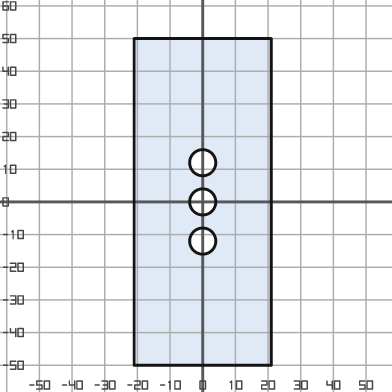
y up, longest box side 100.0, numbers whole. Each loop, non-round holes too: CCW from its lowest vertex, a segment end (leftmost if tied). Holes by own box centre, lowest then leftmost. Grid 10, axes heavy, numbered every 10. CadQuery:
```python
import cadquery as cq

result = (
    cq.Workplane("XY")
    .moveTo(-21.0, -50.0)
    .lineTo(21.0, -50.0)
    .lineTo(21.0, 50.0)
    .lineTo(-21.0, 50.0)
    .close()
    .moveTo(0.0, -12.0)
    .circle(4.0)
    .moveTo(0.0, 0.0)
    .circle(4.0)
    .moveTo(0.0, 12.0)
    .circle(4.0)
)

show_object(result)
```